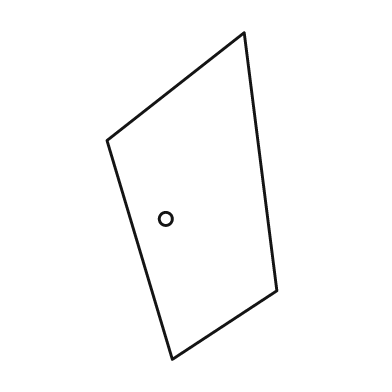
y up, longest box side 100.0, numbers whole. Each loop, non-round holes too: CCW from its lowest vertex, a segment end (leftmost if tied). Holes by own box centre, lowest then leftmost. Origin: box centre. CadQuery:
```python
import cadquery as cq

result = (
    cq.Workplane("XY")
    .moveTo(-6.0, -50.0)
    .lineTo(26.0, -29.0)
    .lineTo(16.0, 50.0)
    .lineTo(-26.0, 17.0)
    .close()
    .moveTo(-8.0, -7.0)
    .circle(2.0)
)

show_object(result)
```